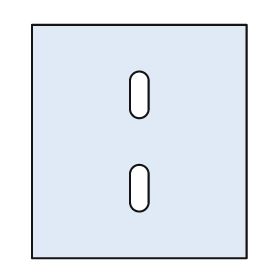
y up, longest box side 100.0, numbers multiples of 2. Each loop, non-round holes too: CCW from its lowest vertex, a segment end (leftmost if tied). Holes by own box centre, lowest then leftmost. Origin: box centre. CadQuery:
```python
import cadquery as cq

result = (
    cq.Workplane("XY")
    .moveTo(-46.0, -50.0)
    .lineTo(46.0, -50.0)
    .lineTo(46.0, 50.0)
    .lineTo(-46.0, 50.0)
    .close()
    .moveTo(-4.0, -26.0)
    .threePointArc((0.0, -30.0), (4.0, -26.0))
    .lineTo(4.0, -14.0)
    .threePointArc((0.0, -10.0), (-4.0, -14.0))
    .close()
    .moveTo(-4.0, 14.0)
    .threePointArc((0.0, 10.0), (4.0, 14.0))
    .lineTo(4.0, 26.0)
    .threePointArc((0.0, 30.0), (-4.0, 26.0))
    .close()
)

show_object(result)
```